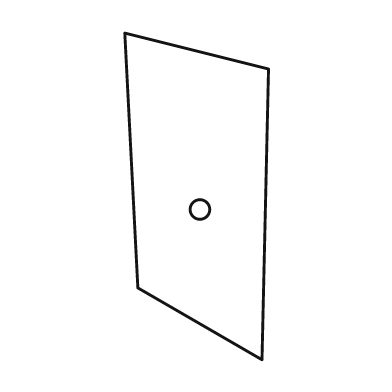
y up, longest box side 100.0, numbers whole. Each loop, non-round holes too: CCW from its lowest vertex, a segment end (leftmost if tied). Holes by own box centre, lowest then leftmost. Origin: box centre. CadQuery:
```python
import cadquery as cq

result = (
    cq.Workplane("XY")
    .moveTo(20.0, -50.0)
    .lineTo(22.0, 39.0)
    .lineTo(-22.0, 50.0)
    .lineTo(-18.0, -28.0)
    .close()
    .moveTo(1.0, -4.0)
    .circle(3.0)
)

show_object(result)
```